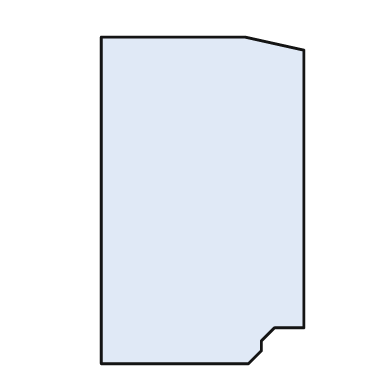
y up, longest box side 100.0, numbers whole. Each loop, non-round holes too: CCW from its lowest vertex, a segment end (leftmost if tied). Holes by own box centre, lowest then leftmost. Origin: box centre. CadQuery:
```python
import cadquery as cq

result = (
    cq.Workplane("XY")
    .moveTo(-31.0, -50.0)
    .lineTo(14.0, -50.0)
    .lineTo(18.0, -46.0)
    .lineTo(18.0, -43.0)
    .lineTo(22.0, -39.0)
    .lineTo(31.0, -39.0)
    .lineTo(31.0, 46.0)
    .lineTo(13.0, 50.0)
    .lineTo(-31.0, 50.0)
    .close()
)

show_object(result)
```